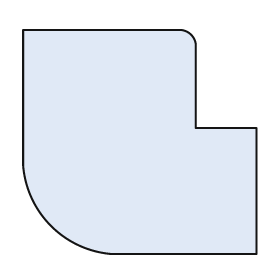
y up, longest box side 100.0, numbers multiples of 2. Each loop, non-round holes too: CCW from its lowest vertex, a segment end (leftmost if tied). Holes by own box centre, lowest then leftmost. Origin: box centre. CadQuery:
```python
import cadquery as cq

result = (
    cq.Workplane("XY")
    .moveTo(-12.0, -48.0)
    .lineTo(50.0, -48.0)
    .lineTo(50.0, 6.0)
    .lineTo(24.0, 6.0)
    .lineTo(24.0, 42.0)
    .threePointArc((22.0, 46.0), (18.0, 48.0))
    .lineTo(-50.0, 48.0)
    .lineTo(-50.0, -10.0)
    .threePointArc((-38.0, -36.0), (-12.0, -48.0))
    .close()
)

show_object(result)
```